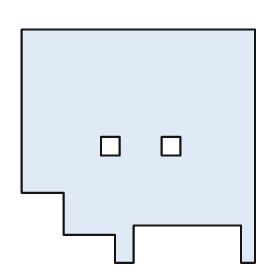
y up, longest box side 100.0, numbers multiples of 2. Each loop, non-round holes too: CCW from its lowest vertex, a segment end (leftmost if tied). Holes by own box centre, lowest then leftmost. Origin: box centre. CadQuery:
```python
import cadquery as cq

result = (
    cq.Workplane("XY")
    .moveTo(-10.0, -50.0)
    .lineTo(-2.0, -50.0)
    .lineTo(-2.0, -34.0)
    .lineTo(44.0, -34.0)
    .lineTo(44.0, -50.0)
    .lineTo(50.0, -50.0)
    .lineTo(50.0, 50.0)
    .lineTo(-50.0, 50.0)
    .lineTo(-50.0, -20.0)
    .lineTo(-32.0, -20.0)
    .lineTo(-32.0, -38.0)
    .lineTo(-10.0, -38.0)
    .close()
    .moveTo(-16.0, -4.0)
    .lineTo(-8.0, -4.0)
    .lineTo(-8.0, 4.0)
    .lineTo(-16.0, 4.0)
    .close()
    .moveTo(10.0, -4.0)
    .lineTo(18.0, -4.0)
    .lineTo(18.0, 4.0)
    .lineTo(10.0, 4.0)
    .close()
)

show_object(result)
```